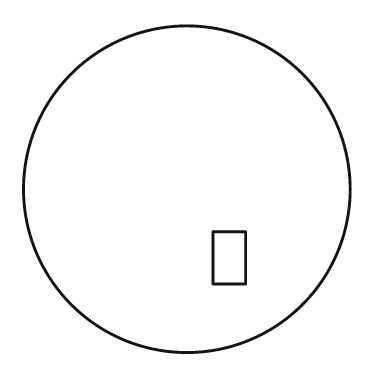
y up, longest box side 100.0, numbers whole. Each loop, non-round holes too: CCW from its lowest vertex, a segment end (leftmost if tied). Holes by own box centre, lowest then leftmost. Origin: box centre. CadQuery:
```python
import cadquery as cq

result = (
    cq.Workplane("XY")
    .moveTo(0.0, 0.0)
    .circle(50.0)
    .moveTo(8.0, -29.0)
    .lineTo(18.0, -29.0)
    .lineTo(18.0, -13.0)
    .lineTo(8.0, -13.0)
    .close()
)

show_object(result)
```